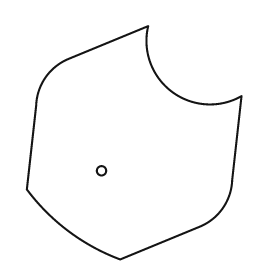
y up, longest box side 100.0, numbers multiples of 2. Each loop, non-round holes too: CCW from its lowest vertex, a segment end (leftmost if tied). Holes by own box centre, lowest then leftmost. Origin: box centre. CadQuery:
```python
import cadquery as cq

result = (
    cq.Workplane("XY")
    .moveTo(-6.0, -50.0)
    .lineTo(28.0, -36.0)
    .threePointArc((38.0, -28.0), (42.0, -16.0))
    .lineTo(46.0, 20.0)
    .threePointArc((16.0, 22.0), (6.0, 50.0))
    .lineTo(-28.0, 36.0)
    .threePointArc((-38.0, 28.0), (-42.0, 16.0))
    .lineTo(-46.0, -20.0)
    .threePointArc((-28.0, -38.0), (-6.0, -50.0))
    .close()
    .moveTo(-14.0, -12.0)
    .circle(2.0)
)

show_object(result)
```